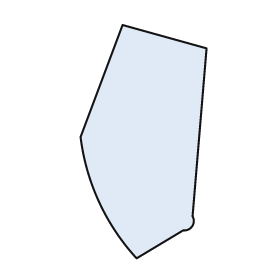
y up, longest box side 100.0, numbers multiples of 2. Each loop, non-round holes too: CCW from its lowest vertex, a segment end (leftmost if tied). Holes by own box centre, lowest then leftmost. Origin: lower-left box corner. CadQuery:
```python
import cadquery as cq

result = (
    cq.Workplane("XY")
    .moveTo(24.0, 0.0)
    .lineTo(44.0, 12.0)
    .threePointArc((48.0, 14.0), (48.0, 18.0))
    .lineTo(54.0, 90.0)
    .lineTo(18.0, 100.0)
    .lineTo(0.0, 52.0)
    .threePointArc((8.0, 24.0), (24.0, 0.0))
    .close()
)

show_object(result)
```